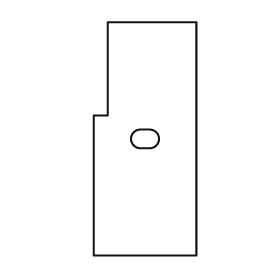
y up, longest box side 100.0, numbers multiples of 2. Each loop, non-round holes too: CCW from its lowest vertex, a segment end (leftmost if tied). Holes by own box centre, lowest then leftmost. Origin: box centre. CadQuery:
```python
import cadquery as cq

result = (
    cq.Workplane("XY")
    .moveTo(-22.0, -50.0)
    .lineTo(22.0, -50.0)
    .lineTo(22.0, 50.0)
    .lineTo(-16.0, 50.0)
    .lineTo(-16.0, 10.0)
    .lineTo(-22.0, 10.0)
    .close()
    .moveTo(-2.0, -4.0)
    .lineTo(2.0, -4.0)
    .threePointArc((6.0, 0.0), (2.0, 4.0))
    .lineTo(-2.0, 4.0)
    .threePointArc((-6.0, 0.0), (-2.0, -4.0))
    .close()
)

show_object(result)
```